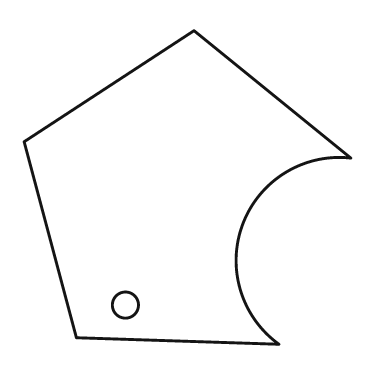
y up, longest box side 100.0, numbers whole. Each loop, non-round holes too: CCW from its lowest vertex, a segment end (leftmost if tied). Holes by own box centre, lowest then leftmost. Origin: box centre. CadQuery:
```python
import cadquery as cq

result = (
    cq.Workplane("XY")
    .moveTo(28.0, -48.0)
    .threePointArc((17.0, -11.0), (50.0, 9.0))
    .lineTo(2.0, 48.0)
    .lineTo(-50.0, 14.0)
    .lineTo(-34.0, -46.0)
    .close()
    .moveTo(-19.0, -36.0)
    .circle(4.0)
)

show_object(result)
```